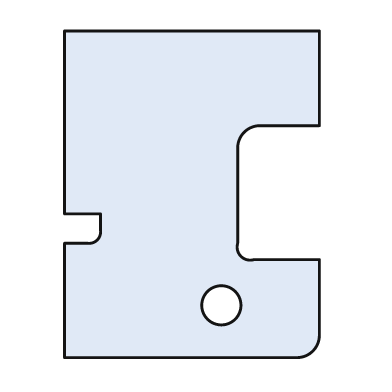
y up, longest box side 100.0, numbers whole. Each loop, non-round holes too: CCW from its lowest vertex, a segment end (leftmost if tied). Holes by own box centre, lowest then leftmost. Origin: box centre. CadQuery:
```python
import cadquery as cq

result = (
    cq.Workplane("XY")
    .moveTo(-39.0, -50.0)
    .lineTo(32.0, -50.0)
    .threePointArc((37.0, -48.0), (39.0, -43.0))
    .lineTo(39.0, -20.0)
    .lineTo(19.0, -20.0)
    .threePointArc((15.0, -19.0), (14.0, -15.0))
    .lineTo(14.0, 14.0)
    .threePointArc((16.0, 19.0), (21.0, 21.0))
    .lineTo(39.0, 21.0)
    .lineTo(39.0, 50.0)
    .lineTo(-39.0, 50.0)
    .lineTo(-39.0, -6.0)
    .lineTo(-28.0, -6.0)
    .lineTo(-28.0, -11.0)
    .threePointArc((-29.0, -14.0), (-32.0, -15.0))
    .lineTo(-39.0, -15.0)
    .close()
    .moveTo(9.0, -34.0)
    .circle(6.0)
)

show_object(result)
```